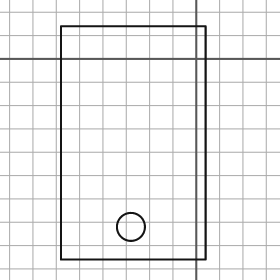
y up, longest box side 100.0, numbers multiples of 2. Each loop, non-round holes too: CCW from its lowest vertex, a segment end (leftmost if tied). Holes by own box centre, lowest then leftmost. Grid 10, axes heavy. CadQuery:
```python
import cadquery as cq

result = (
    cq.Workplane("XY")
    .moveTo(-58.0, -86.0)
    .lineTo(4.0, -86.0)
    .lineTo(4.0, 14.0)
    .lineTo(-58.0, 14.0)
    .close()
    .moveTo(-28.0, -72.0)
    .circle(6.0)
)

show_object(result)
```